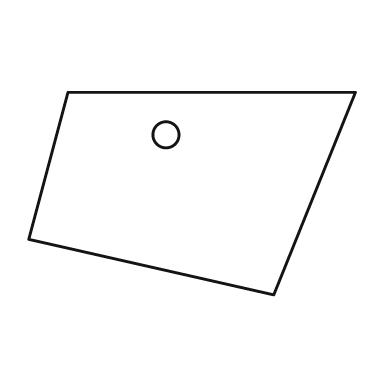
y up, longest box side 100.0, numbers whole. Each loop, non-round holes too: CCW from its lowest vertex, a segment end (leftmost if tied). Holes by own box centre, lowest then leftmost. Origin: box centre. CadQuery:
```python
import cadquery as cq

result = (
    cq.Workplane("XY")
    .moveTo(25.0, -31.0)
    .lineTo(50.0, 31.0)
    .lineTo(-38.0, 31.0)
    .lineTo(-50.0, -14.0)
    .close()
    .moveTo(-8.0, 18.0)
    .circle(4.0)
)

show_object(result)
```